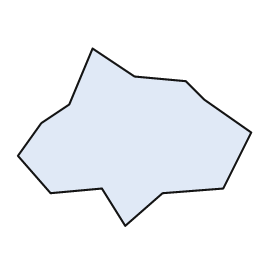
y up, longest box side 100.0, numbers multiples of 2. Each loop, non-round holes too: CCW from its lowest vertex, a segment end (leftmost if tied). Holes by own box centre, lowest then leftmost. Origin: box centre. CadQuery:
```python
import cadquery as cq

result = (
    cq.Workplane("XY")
    .moveTo(-4.0, -38.0)
    .lineTo(12.0, -24.0)
    .lineTo(38.0, -22.0)
    .lineTo(50.0, 2.0)
    .lineTo(30.0, 16.0)
    .lineTo(22.0, 24.0)
    .lineTo(0.0, 26.0)
    .lineTo(-18.0, 38.0)
    .lineTo(-28.0, 14.0)
    .lineTo(-40.0, 6.0)
    .lineTo(-50.0, -8.0)
    .lineTo(-36.0, -24.0)
    .lineTo(-14.0, -22.0)
    .close()
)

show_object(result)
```